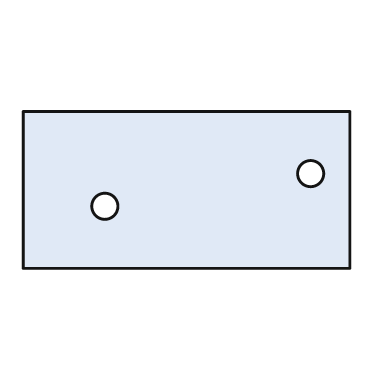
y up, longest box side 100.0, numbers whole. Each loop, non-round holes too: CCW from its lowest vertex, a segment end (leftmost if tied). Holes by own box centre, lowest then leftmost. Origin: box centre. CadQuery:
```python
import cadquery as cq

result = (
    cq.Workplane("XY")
    .moveTo(-50.0, -24.0)
    .lineTo(50.0, -24.0)
    .lineTo(50.0, 24.0)
    .lineTo(-50.0, 24.0)
    .close()
    .moveTo(-25.0, -5.0)
    .circle(4.0)
    .moveTo(38.0, 5.0)
    .circle(4.0)
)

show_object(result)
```